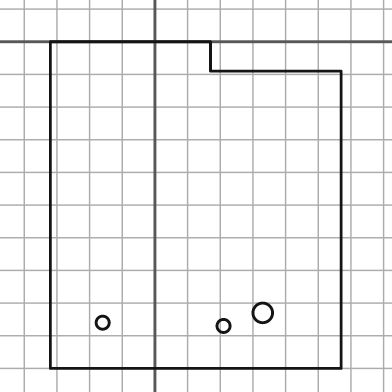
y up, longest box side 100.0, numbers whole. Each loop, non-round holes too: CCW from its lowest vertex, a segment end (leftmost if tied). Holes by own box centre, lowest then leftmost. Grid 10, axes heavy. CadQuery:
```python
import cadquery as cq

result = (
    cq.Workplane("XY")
    .moveTo(-32.0, -100.0)
    .lineTo(57.0, -100.0)
    .lineTo(57.0, -9.0)
    .lineTo(17.0, -9.0)
    .lineTo(17.0, 0.0)
    .lineTo(-32.0, 0.0)
    .close()
    .moveTo(21.0, -87.0)
    .circle(2.0)
    .moveTo(-16.0, -86.0)
    .circle(2.0)
    .moveTo(33.0, -83.0)
    .circle(3.0)
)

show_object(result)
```